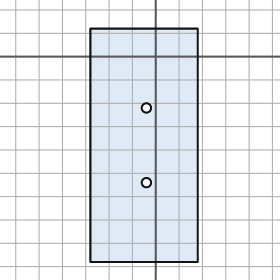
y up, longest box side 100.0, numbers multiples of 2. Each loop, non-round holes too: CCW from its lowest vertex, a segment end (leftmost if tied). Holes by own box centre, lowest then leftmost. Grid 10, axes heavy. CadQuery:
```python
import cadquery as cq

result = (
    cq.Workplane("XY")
    .moveTo(-28.0, -88.0)
    .lineTo(18.0, -88.0)
    .lineTo(18.0, 12.0)
    .lineTo(-28.0, 12.0)
    .close()
    .moveTo(-4.0, -54.0)
    .circle(2.0)
    .moveTo(-4.0, -22.0)
    .circle(2.0)
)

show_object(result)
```